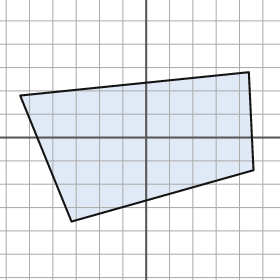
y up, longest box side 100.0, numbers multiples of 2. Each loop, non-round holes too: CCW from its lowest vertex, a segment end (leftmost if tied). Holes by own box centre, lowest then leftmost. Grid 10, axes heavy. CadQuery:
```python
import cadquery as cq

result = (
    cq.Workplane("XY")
    .moveTo(-32.0, -36.0)
    .lineTo(46.0, -14.0)
    .lineTo(44.0, 28.0)
    .lineTo(-54.0, 18.0)
    .close()
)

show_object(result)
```